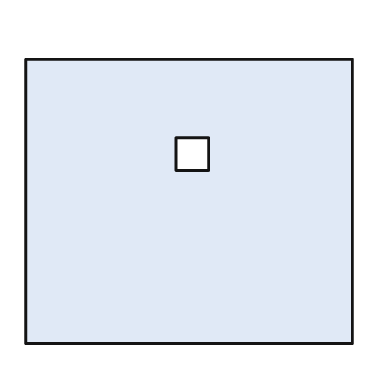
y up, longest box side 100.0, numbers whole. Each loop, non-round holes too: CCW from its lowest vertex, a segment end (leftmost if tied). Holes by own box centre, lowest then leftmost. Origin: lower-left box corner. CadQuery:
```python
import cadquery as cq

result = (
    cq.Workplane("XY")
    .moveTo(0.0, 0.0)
    .lineTo(100.0, 0.0)
    .lineTo(100.0, 87.0)
    .lineTo(0.0, 87.0)
    .close()
    .moveTo(46.0, 53.0)
    .lineTo(56.0, 53.0)
    .lineTo(56.0, 63.0)
    .lineTo(46.0, 63.0)
    .close()
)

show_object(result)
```